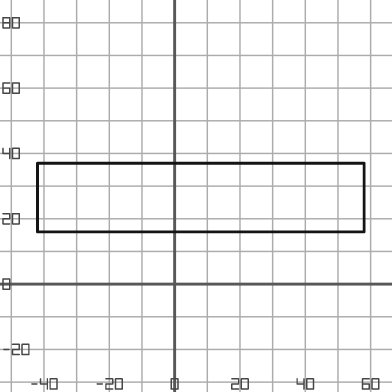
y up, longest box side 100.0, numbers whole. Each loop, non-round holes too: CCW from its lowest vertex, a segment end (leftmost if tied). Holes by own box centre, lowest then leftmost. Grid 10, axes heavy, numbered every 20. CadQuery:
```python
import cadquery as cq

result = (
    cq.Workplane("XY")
    .moveTo(-42.0, 16.0)
    .lineTo(58.0, 16.0)
    .lineTo(58.0, 37.0)
    .lineTo(-42.0, 37.0)
    .close()
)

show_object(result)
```